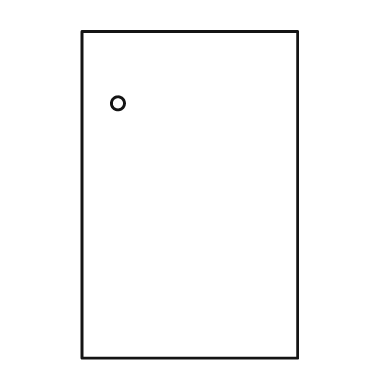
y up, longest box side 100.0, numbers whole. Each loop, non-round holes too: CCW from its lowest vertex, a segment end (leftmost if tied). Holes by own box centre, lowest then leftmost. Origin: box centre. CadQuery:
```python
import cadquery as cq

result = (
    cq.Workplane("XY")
    .moveTo(-33.0, -50.0)
    .lineTo(33.0, -50.0)
    .lineTo(33.0, 50.0)
    .lineTo(-33.0, 50.0)
    .close()
    .moveTo(-22.0, 28.0)
    .circle(2.0)
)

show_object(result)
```